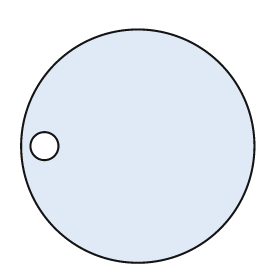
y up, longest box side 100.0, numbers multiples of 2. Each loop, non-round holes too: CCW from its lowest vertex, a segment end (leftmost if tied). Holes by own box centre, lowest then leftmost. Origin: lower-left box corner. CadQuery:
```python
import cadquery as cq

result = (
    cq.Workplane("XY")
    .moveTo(50.0, 50.0)
    .circle(50.0)
    .moveTo(10.0, 50.0)
    .circle(6.0)
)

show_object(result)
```